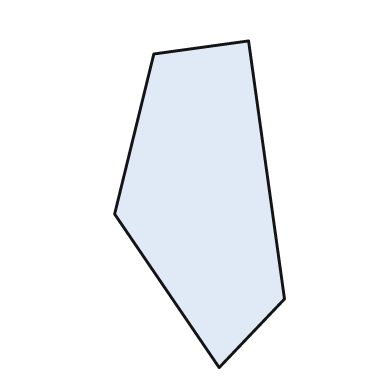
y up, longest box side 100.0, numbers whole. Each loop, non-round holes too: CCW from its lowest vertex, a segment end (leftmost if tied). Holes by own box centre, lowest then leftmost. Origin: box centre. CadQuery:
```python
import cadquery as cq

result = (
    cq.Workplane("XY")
    .moveTo(6.0, -50.0)
    .lineTo(26.0, -29.0)
    .lineTo(15.0, 50.0)
    .lineTo(-14.0, 46.0)
    .lineTo(-26.0, -3.0)
    .close()
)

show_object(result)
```